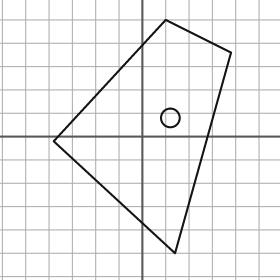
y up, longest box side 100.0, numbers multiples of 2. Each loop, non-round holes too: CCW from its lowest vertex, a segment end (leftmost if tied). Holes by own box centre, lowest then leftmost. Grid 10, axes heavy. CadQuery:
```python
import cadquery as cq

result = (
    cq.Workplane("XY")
    .moveTo(14.0, -50.0)
    .lineTo(38.0, 36.0)
    .lineTo(10.0, 50.0)
    .lineTo(-38.0, -2.0)
    .close()
    .moveTo(12.0, 8.0)
    .circle(4.0)
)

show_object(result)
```